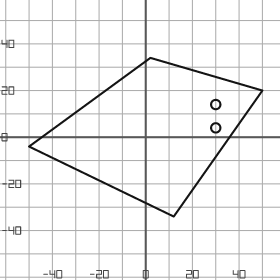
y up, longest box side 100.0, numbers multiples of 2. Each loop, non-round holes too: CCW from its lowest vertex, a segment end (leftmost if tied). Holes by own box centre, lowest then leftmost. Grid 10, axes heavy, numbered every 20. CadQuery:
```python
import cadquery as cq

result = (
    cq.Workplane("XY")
    .moveTo(12.0, -34.0)
    .lineTo(50.0, 20.0)
    .lineTo(2.0, 34.0)
    .lineTo(-50.0, -4.0)
    .close()
    .moveTo(30.0, 4.0)
    .circle(2.0)
    .moveTo(30.0, 14.0)
    .circle(2.0)
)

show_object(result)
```